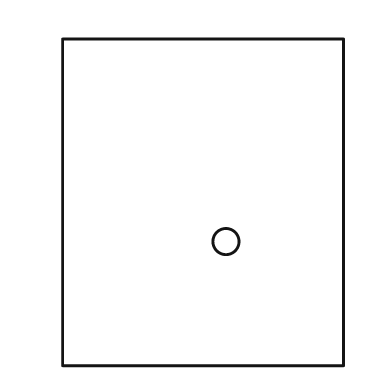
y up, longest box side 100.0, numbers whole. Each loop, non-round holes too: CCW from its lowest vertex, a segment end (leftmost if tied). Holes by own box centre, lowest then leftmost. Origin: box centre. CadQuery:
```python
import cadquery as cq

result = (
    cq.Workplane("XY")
    .moveTo(-43.0, -50.0)
    .lineTo(43.0, -50.0)
    .lineTo(43.0, 50.0)
    .lineTo(-43.0, 50.0)
    .close()
    .moveTo(7.0, -12.0)
    .circle(4.0)
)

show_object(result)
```